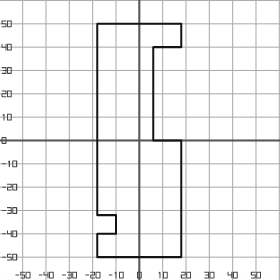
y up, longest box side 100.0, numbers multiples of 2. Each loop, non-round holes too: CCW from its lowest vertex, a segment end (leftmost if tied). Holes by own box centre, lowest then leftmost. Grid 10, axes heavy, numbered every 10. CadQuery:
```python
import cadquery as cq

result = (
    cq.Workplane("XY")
    .moveTo(-18.0, -50.0)
    .lineTo(18.0, -50.0)
    .lineTo(18.0, 0.0)
    .lineTo(6.0, 0.0)
    .lineTo(6.0, 40.0)
    .lineTo(18.0, 40.0)
    .lineTo(18.0, 50.0)
    .lineTo(-18.0, 50.0)
    .lineTo(-18.0, -32.0)
    .lineTo(-10.0, -32.0)
    .lineTo(-10.0, -40.0)
    .lineTo(-18.0, -40.0)
    .close()
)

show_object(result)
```